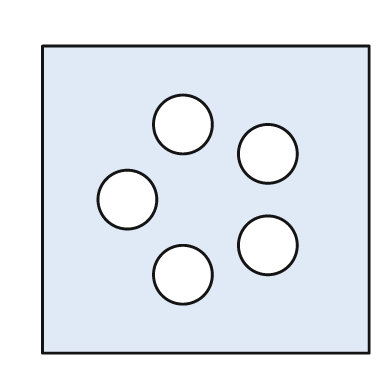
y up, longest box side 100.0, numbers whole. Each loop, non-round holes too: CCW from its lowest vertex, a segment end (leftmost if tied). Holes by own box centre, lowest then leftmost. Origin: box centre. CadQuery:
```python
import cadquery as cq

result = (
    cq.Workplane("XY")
    .moveTo(-50.0, -47.0)
    .lineTo(50.0, -47.0)
    .lineTo(50.0, 47.0)
    .lineTo(-50.0, 47.0)
    .close()
    .moveTo(-7.0, -23.0)
    .circle(9.0)
    .moveTo(19.0, -14.0)
    .circle(9.0)
    .moveTo(-24.0, 0.0)
    .circle(9.0)
    .moveTo(19.0, 14.0)
    .circle(9.0)
    .moveTo(-7.0, 23.0)
    .circle(9.0)
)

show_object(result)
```